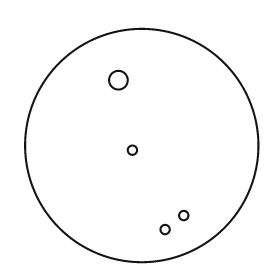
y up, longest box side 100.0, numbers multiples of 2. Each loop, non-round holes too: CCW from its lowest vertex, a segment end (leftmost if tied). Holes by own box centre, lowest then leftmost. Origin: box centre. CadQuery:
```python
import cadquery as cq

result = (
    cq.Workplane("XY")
    .moveTo(0.0, 0.0)
    .circle(50.0)
    .moveTo(10.0, -36.0)
    .circle(2.0)
    .moveTo(18.0, -30.0)
    .circle(2.0)
    .moveTo(-4.0, -2.0)
    .circle(2.0)
    .moveTo(-10.0, 28.0)
    .circle(4.0)
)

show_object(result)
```